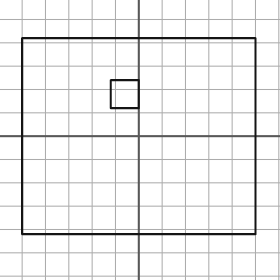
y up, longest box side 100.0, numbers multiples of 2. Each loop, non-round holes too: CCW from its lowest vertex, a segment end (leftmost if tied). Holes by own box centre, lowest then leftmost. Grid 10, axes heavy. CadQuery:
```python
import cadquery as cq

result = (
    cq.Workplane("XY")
    .moveTo(-50.0, -42.0)
    .lineTo(50.0, -42.0)
    .lineTo(50.0, 42.0)
    .lineTo(-50.0, 42.0)
    .close()
    .moveTo(-12.0, 12.0)
    .lineTo(0.0, 12.0)
    .lineTo(0.0, 24.0)
    .lineTo(-12.0, 24.0)
    .close()
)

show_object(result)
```